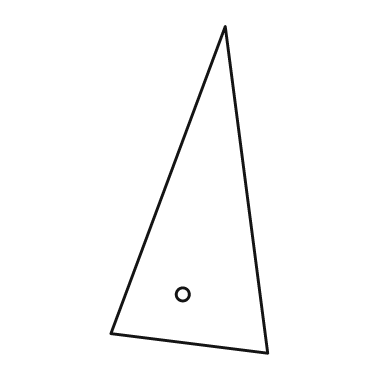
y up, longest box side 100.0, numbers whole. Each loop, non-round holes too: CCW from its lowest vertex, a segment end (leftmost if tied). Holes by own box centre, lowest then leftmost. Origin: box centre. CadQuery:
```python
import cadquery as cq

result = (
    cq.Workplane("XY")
    .moveTo(24.0, -50.0)
    .lineTo(11.0, 50.0)
    .lineTo(-24.0, -44.0)
    .close()
    .moveTo(-2.0, -32.0)
    .circle(2.0)
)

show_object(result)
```